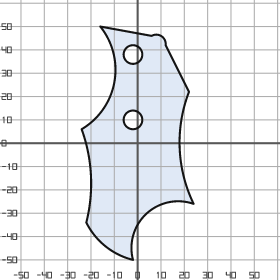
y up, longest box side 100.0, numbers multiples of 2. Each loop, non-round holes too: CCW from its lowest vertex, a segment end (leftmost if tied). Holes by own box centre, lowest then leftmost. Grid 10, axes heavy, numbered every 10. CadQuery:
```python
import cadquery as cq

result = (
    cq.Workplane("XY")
    .moveTo(-2.0, -50.0)
    .threePointArc((4.0, -30.0), (24.0, -26.0))
    .threePointArc((18.0, -2.0), (22.0, 22.0))
    .lineTo(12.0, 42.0)
    .threePointArc((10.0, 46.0), (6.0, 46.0))
    .lineTo(-16.0, 50.0)
    .threePointArc((-10.0, 26.0), (-24.0, 6.0))
    .threePointArc((-20.0, -14.0), (-22.0, -34.0))
    .threePointArc((-14.0, -44.0), (-2.0, -50.0))
    .close()
    .moveTo(-2.0, 10.0)
    .circle(4.0)
    .moveTo(-2.0, 38.0)
    .circle(4.0)
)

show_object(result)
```